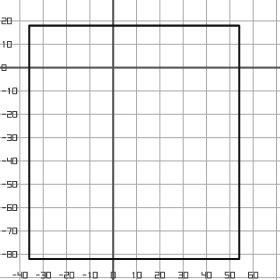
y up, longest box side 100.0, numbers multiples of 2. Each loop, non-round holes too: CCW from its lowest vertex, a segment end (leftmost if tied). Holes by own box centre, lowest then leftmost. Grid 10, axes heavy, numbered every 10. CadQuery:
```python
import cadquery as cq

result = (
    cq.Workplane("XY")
    .moveTo(-36.0, -82.0)
    .lineTo(54.0, -82.0)
    .lineTo(54.0, 18.0)
    .lineTo(-36.0, 18.0)
    .close()
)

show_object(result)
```